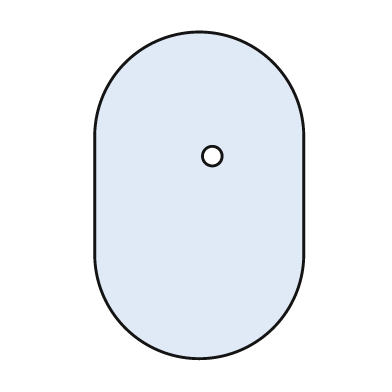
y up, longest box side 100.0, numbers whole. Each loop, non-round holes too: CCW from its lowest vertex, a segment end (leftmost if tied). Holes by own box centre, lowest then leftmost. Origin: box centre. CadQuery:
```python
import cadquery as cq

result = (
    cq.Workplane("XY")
    .moveTo(-32.0, -18.0)
    .threePointArc((0.0, -50.0), (32.0, -18.0))
    .lineTo(32.0, 18.0)
    .threePointArc((0.0, 50.0), (-32.0, 18.0))
    .close()
    .moveTo(4.0, 12.0)
    .circle(3.0)
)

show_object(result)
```